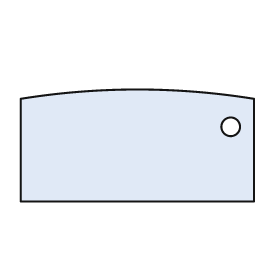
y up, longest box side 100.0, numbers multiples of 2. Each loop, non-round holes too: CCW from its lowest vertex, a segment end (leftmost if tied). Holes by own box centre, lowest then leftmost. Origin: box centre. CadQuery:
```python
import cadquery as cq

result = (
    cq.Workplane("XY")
    .moveTo(-50.0, -24.0)
    .lineTo(50.0, -24.0)
    .lineTo(50.0, 20.0)
    .threePointArc((0.0, 24.0), (-50.0, 20.0))
    .close()
    .moveTo(40.0, 8.0)
    .circle(4.0)
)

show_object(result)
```